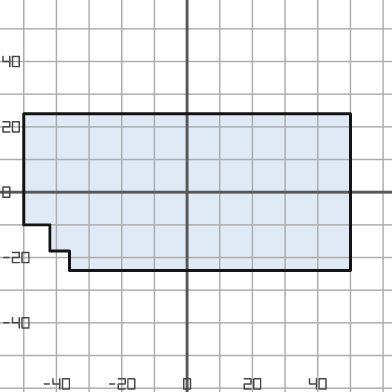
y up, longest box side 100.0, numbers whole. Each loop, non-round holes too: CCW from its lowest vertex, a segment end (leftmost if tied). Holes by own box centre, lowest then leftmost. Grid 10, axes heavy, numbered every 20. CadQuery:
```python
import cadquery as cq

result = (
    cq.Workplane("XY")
    .moveTo(-36.0, -24.0)
    .lineTo(50.0, -24.0)
    .lineTo(50.0, 24.0)
    .lineTo(-50.0, 24.0)
    .lineTo(-50.0, -10.0)
    .lineTo(-42.0, -10.0)
    .lineTo(-42.0, -18.0)
    .lineTo(-36.0, -18.0)
    .close()
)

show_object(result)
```